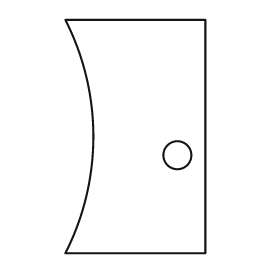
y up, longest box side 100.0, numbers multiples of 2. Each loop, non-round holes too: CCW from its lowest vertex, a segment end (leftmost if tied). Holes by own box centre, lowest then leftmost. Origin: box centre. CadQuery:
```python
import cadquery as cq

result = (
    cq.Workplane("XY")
    .moveTo(-30.0, -50.0)
    .lineTo(30.0, -50.0)
    .lineTo(30.0, 50.0)
    .lineTo(-30.0, 50.0)
    .threePointArc((-18.0, 0.0), (-30.0, -50.0))
    .close()
    .moveTo(18.0, -8.0)
    .circle(6.0)
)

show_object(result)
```